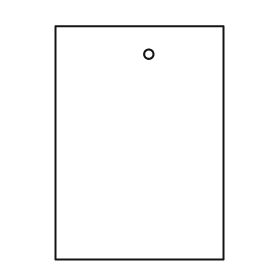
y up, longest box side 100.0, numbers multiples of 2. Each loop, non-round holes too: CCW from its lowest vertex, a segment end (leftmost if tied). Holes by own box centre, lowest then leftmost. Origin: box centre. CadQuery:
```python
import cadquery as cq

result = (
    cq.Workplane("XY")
    .moveTo(-36.0, -50.0)
    .lineTo(36.0, -50.0)
    .lineTo(36.0, 50.0)
    .lineTo(-36.0, 50.0)
    .close()
    .moveTo(4.0, 38.0)
    .circle(2.0)
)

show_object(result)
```